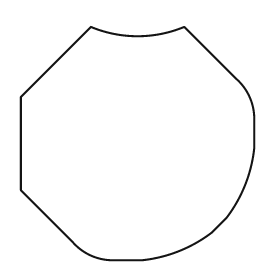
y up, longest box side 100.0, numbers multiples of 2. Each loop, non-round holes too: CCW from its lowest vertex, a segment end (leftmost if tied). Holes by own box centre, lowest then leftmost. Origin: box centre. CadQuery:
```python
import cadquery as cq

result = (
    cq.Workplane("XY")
    .moveTo(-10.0, -50.0)
    .lineTo(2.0, -50.0)
    .threePointArc((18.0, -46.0), (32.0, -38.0))
    .lineTo(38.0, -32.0)
    .threePointArc((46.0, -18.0), (50.0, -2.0))
    .lineTo(50.0, 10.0)
    .threePointArc((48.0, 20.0), (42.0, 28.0))
    .lineTo(20.0, 50.0)
    .threePointArc((0.0, 46.0), (-20.0, 50.0))
    .lineTo(-50.0, 20.0)
    .lineTo(-50.0, -20.0)
    .lineTo(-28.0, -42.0)
    .threePointArc((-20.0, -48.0), (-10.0, -50.0))
    .close()
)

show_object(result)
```